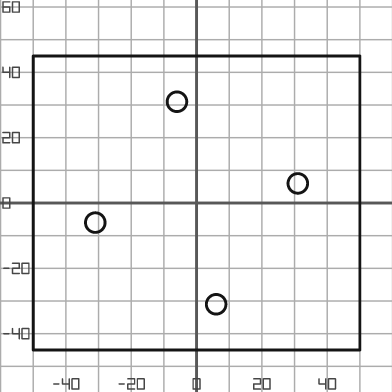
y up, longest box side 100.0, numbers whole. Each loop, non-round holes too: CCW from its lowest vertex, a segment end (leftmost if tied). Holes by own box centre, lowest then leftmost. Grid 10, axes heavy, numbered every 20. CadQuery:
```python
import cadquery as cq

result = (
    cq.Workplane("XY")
    .moveTo(-50.0, -45.0)
    .lineTo(50.0, -45.0)
    .lineTo(50.0, 45.0)
    .lineTo(-50.0, 45.0)
    .close()
    .moveTo(6.0, -31.0)
    .circle(3.0)
    .moveTo(-31.0, -6.0)
    .circle(3.0)
    .moveTo(31.0, 6.0)
    .circle(3.0)
    .moveTo(-6.0, 31.0)
    .circle(3.0)
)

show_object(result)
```